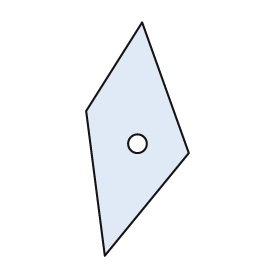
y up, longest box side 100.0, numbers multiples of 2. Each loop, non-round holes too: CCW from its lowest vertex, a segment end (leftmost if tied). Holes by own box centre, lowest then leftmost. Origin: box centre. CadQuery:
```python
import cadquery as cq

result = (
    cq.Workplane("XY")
    .moveTo(-14.0, -50.0)
    .lineTo(22.0, -6.0)
    .lineTo(2.0, 50.0)
    .lineTo(-22.0, 12.0)
    .close()
    .moveTo(0.0, -2.0)
    .circle(4.0)
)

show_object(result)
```